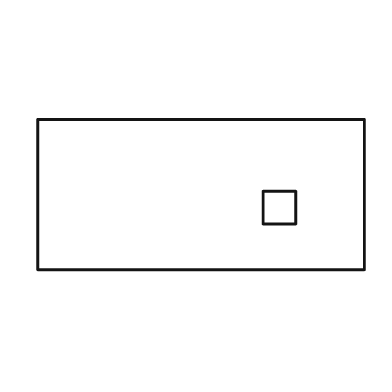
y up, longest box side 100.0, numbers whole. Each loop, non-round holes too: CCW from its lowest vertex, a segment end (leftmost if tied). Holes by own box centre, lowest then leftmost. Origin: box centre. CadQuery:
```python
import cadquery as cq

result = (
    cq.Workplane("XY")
    .moveTo(-50.0, -23.0)
    .lineTo(50.0, -23.0)
    .lineTo(50.0, 23.0)
    .lineTo(-50.0, 23.0)
    .close()
    .moveTo(19.0, -9.0)
    .lineTo(29.0, -9.0)
    .lineTo(29.0, 1.0)
    .lineTo(19.0, 1.0)
    .close()
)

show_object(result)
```